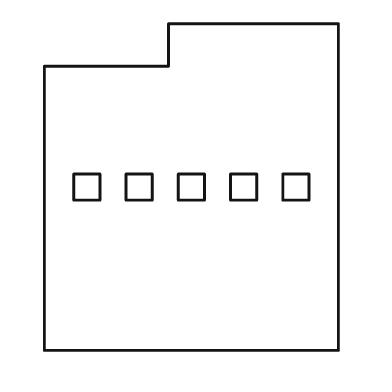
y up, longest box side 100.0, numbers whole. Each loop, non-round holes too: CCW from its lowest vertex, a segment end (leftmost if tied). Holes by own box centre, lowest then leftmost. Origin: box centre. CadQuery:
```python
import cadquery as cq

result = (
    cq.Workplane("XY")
    .moveTo(-45.0, -50.0)
    .lineTo(45.0, -50.0)
    .lineTo(45.0, 50.0)
    .lineTo(-7.0, 50.0)
    .lineTo(-7.0, 37.0)
    .lineTo(-45.0, 37.0)
    .close()
    .moveTo(-36.0, -4.0)
    .lineTo(-28.0, -4.0)
    .lineTo(-28.0, 4.0)
    .lineTo(-36.0, 4.0)
    .close()
    .moveTo(-20.0, -4.0)
    .lineTo(-12.0, -4.0)
    .lineTo(-12.0, 4.0)
    .lineTo(-20.0, 4.0)
    .close()
    .moveTo(-4.0, -4.0)
    .lineTo(4.0, -4.0)
    .lineTo(4.0, 4.0)
    .lineTo(-4.0, 4.0)
    .close()
    .moveTo(12.0, -4.0)
    .lineTo(20.0, -4.0)
    .lineTo(20.0, 4.0)
    .lineTo(12.0, 4.0)
    .close()
    .moveTo(28.0, -4.0)
    .lineTo(36.0, -4.0)
    .lineTo(36.0, 4.0)
    .lineTo(28.0, 4.0)
    .close()
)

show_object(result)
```